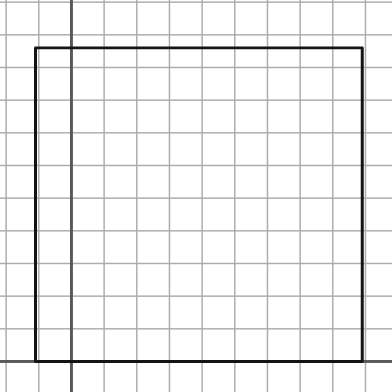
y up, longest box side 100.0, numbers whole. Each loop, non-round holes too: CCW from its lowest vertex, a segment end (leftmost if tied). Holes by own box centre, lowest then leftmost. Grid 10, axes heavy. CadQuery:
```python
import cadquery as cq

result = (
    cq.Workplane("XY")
    .moveTo(-11.0, 0.0)
    .lineTo(89.0, 0.0)
    .lineTo(89.0, 96.0)
    .lineTo(-11.0, 96.0)
    .close()
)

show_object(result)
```